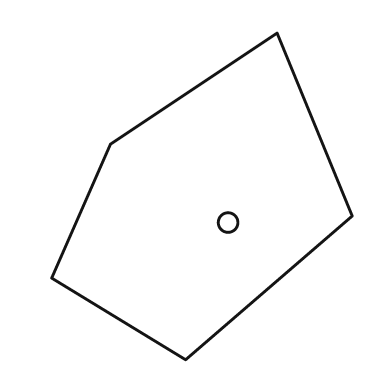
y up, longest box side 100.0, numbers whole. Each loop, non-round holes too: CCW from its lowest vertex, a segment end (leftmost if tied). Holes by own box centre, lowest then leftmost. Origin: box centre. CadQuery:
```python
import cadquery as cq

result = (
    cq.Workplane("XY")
    .moveTo(-5.0, -50.0)
    .lineTo(46.0, -6.0)
    .lineTo(23.0, 50.0)
    .lineTo(-28.0, 16.0)
    .lineTo(-46.0, -25.0)
    .close()
    .moveTo(8.0, -8.0)
    .circle(3.0)
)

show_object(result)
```